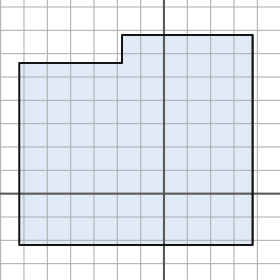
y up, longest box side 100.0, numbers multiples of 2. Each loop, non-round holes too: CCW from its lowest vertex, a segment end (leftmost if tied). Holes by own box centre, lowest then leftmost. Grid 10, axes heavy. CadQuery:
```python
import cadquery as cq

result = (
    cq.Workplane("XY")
    .moveTo(-62.0, -22.0)
    .lineTo(38.0, -22.0)
    .lineTo(38.0, 68.0)
    .lineTo(-18.0, 68.0)
    .lineTo(-18.0, 56.0)
    .lineTo(-62.0, 56.0)
    .close()
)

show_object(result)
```